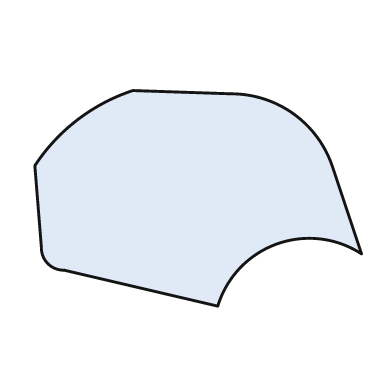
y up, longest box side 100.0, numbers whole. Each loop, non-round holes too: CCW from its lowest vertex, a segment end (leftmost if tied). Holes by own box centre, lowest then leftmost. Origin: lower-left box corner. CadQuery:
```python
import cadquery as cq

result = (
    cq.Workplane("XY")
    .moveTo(56.0, 0.0)
    .threePointArc((74.0, 19.0), (100.0, 16.0))
    .lineTo(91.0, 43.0)
    .threePointArc((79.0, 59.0), (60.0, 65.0))
    .lineTo(30.0, 66.0)
    .threePointArc((13.0, 57.0), (0.0, 43.0))
    .lineTo(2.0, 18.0)
    .threePointArc((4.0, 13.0), (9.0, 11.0))
    .close()
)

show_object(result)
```